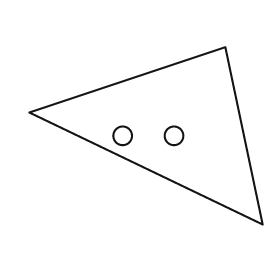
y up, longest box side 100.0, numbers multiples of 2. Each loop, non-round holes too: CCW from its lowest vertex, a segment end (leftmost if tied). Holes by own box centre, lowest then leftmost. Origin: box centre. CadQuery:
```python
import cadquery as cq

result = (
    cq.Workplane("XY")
    .moveTo(50.0, -38.0)
    .lineTo(34.0, 38.0)
    .lineTo(-50.0, 10.0)
    .close()
    .moveTo(-10.0, 0.0)
    .circle(4.0)
    .moveTo(12.0, 0.0)
    .circle(4.0)
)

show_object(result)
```